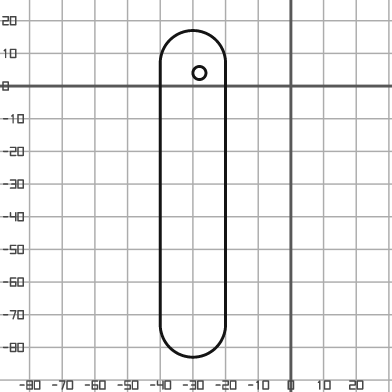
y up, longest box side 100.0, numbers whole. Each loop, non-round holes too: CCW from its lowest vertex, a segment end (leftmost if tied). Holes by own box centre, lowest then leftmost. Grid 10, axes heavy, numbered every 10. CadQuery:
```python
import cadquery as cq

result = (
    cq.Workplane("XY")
    .moveTo(-40.0, -73.0)
    .threePointArc((-30.0, -83.0), (-20.0, -73.0))
    .lineTo(-20.0, 7.0)
    .threePointArc((-30.0, 17.0), (-40.0, 7.0))
    .close()
    .moveTo(-28.0, 4.0)
    .circle(2.0)
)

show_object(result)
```